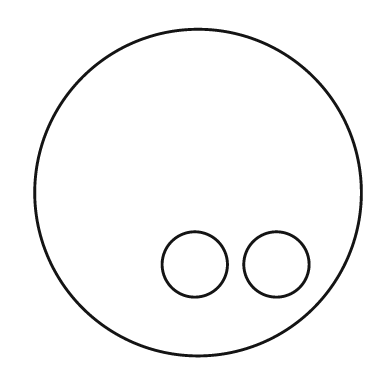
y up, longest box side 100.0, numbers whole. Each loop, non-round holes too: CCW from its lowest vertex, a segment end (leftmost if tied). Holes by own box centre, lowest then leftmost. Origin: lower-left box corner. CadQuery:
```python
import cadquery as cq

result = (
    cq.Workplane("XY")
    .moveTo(50.0, 50.0)
    .circle(50.0)
    .moveTo(49.0, 28.0)
    .circle(10.0)
    .moveTo(74.0, 28.0)
    .circle(10.0)
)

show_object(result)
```